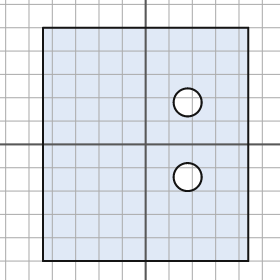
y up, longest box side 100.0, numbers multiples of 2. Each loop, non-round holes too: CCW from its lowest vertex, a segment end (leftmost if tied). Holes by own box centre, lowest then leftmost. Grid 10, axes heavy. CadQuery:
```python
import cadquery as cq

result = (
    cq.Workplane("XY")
    .moveTo(-44.0, -50.0)
    .lineTo(44.0, -50.0)
    .lineTo(44.0, 50.0)
    .lineTo(-44.0, 50.0)
    .close()
    .moveTo(18.0, -14.0)
    .circle(6.0)
    .moveTo(18.0, 18.0)
    .circle(6.0)
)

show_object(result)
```